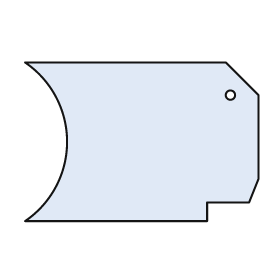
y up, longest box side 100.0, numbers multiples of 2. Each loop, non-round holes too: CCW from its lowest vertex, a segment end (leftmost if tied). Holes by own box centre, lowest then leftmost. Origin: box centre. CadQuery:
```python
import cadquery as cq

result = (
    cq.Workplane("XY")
    .moveTo(-50.0, -34.0)
    .lineTo(28.0, -34.0)
    .lineTo(28.0, -26.0)
    .lineTo(46.0, -26.0)
    .lineTo(50.0, -16.0)
    .lineTo(50.0, 20.0)
    .lineTo(36.0, 34.0)
    .lineTo(-50.0, 34.0)
    .threePointArc((-32.0, 0.0), (-50.0, -34.0))
    .close()
    .moveTo(38.0, 20.0)
    .circle(2.0)
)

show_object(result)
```